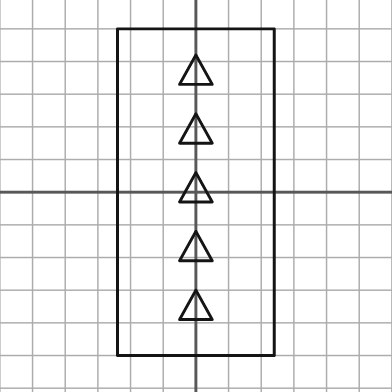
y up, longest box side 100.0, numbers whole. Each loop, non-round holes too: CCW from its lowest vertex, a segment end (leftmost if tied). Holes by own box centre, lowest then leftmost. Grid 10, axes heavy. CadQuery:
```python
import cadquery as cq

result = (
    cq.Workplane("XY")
    .moveTo(-24.0, -50.0)
    .lineTo(24.0, -50.0)
    .lineTo(24.0, 50.0)
    .lineTo(-24.0, 50.0)
    .close()
    .moveTo(-5.0, -39.0)
    .lineTo(5.0, -39.0)
    .lineTo(0.0, -30.0)
    .close()
    .moveTo(-5.0, -21.0)
    .lineTo(5.0, -21.0)
    .lineTo(0.0, -12.0)
    .close()
    .moveTo(-5.0, -3.0)
    .lineTo(5.0, -3.0)
    .lineTo(0.0, 6.0)
    .close()
    .moveTo(-5.0, 15.0)
    .lineTo(5.0, 15.0)
    .lineTo(0.0, 24.0)
    .close()
    .moveTo(-5.0, 33.0)
    .lineTo(5.0, 33.0)
    .lineTo(0.0, 42.0)
    .close()
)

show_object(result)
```